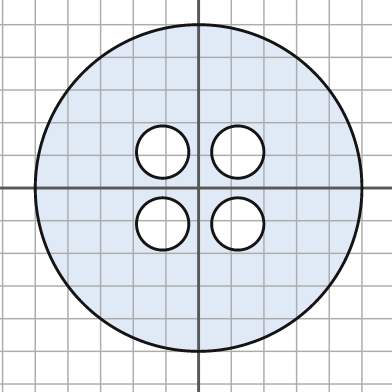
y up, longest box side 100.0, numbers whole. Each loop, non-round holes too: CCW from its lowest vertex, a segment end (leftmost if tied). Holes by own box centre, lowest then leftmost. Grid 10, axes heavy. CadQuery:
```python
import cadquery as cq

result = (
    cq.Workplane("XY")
    .moveTo(0.0, 0.0)
    .circle(50.0)
    .moveTo(-11.0, -11.0)
    .circle(8.0)
    .moveTo(12.0, -11.0)
    .circle(8.0)
    .moveTo(-11.0, 11.0)
    .circle(8.0)
    .moveTo(12.0, 11.0)
    .circle(8.0)
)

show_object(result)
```